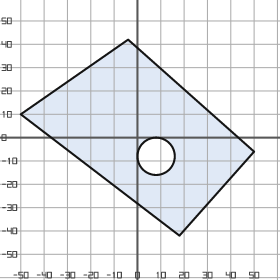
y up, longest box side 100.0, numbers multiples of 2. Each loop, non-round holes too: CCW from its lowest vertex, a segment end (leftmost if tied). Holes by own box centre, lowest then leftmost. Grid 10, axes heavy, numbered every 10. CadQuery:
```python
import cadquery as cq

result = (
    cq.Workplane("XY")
    .moveTo(18.0, -42.0)
    .lineTo(50.0, -6.0)
    .lineTo(-4.0, 42.0)
    .lineTo(-50.0, 10.0)
    .close()
    .moveTo(8.0, -8.0)
    .circle(8.0)
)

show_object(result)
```